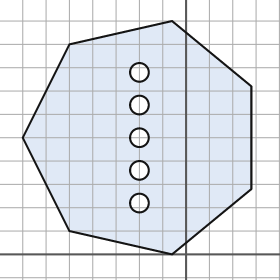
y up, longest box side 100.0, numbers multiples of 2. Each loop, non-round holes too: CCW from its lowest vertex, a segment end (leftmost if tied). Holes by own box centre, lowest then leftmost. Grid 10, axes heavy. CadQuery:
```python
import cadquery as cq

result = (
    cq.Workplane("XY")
    .moveTo(-6.0, 0.0)
    .lineTo(28.0, 28.0)
    .lineTo(28.0, 72.0)
    .lineTo(-6.0, 100.0)
    .lineTo(-50.0, 90.0)
    .lineTo(-70.0, 50.0)
    .lineTo(-50.0, 10.0)
    .close()
    .moveTo(-20.0, 22.0)
    .circle(4.0)
    .moveTo(-20.0, 36.0)
    .circle(4.0)
    .moveTo(-20.0, 50.0)
    .circle(4.0)
    .moveTo(-20.0, 64.0)
    .circle(4.0)
    .moveTo(-20.0, 78.0)
    .circle(4.0)
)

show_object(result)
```